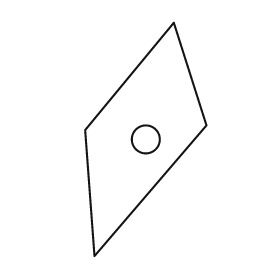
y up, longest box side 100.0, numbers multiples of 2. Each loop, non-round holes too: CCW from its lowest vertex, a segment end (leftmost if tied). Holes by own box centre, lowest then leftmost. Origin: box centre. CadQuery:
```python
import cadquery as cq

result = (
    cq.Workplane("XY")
    .moveTo(-22.0, -50.0)
    .lineTo(26.0, 6.0)
    .lineTo(12.0, 50.0)
    .lineTo(-26.0, 4.0)
    .close()
    .moveTo(0.0, 0.0)
    .circle(6.0)
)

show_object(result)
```